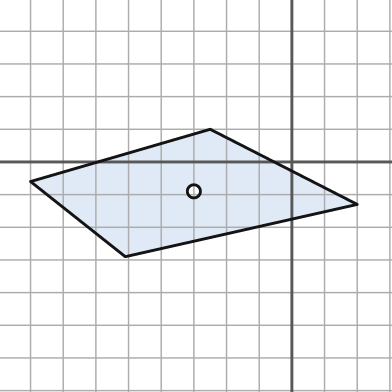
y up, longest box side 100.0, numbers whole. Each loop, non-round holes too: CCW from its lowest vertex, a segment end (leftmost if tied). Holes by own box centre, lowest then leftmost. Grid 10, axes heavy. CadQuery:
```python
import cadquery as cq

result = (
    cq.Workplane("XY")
    .moveTo(-51.0, -29.0)
    .lineTo(20.0, -13.0)
    .lineTo(-25.0, 10.0)
    .lineTo(-80.0, -6.0)
    .close()
    .moveTo(-30.0, -9.0)
    .circle(2.0)
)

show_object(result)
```